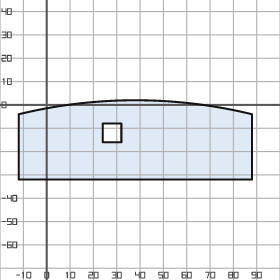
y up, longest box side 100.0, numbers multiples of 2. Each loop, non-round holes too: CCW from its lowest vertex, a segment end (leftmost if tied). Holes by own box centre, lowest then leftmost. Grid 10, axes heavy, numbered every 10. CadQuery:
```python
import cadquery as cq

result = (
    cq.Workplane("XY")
    .moveTo(-12.0, -32.0)
    .lineTo(88.0, -32.0)
    .lineTo(88.0, -4.0)
    .threePointArc((38.0, 2.0), (-12.0, -4.0))
    .close()
    .moveTo(24.0, -16.0)
    .lineTo(32.0, -16.0)
    .lineTo(32.0, -8.0)
    .lineTo(24.0, -8.0)
    .close()
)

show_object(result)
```